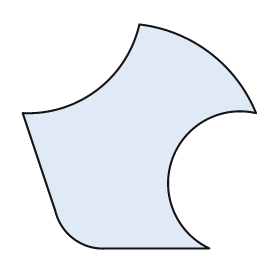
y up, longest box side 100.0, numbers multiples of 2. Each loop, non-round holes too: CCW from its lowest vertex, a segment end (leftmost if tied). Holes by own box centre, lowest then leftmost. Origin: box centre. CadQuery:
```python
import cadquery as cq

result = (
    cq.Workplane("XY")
    .moveTo(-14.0, -48.0)
    .lineTo(30.0, -48.0)
    .threePointArc((14.0, -10.0), (50.0, 10.0))
    .threePointArc((30.0, 36.0), (0.0, 48.0))
    .threePointArc((-18.0, 20.0), (-50.0, 10.0))
    .lineTo(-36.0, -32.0)
    .threePointArc((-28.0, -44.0), (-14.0, -48.0))
    .close()
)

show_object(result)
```